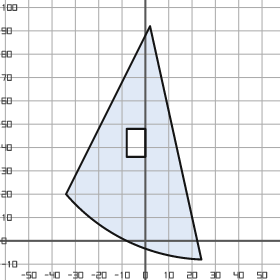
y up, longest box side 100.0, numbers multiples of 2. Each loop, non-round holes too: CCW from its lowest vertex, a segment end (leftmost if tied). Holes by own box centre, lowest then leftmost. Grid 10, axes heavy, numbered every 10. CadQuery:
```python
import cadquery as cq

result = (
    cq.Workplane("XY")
    .moveTo(24.0, -8.0)
    .lineTo(2.0, 92.0)
    .lineTo(-34.0, 20.0)
    .threePointArc((-8.0, 0.0), (24.0, -8.0))
    .close()
    .moveTo(-8.0, 36.0)
    .lineTo(0.0, 36.0)
    .lineTo(0.0, 48.0)
    .lineTo(-8.0, 48.0)
    .close()
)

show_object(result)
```